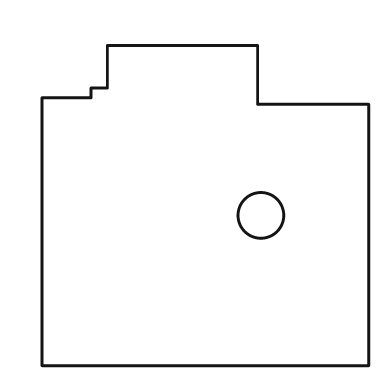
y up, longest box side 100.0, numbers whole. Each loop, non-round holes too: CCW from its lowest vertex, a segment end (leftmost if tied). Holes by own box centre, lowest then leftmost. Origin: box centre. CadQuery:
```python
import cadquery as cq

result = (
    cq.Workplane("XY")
    .moveTo(-50.0, -49.0)
    .lineTo(50.0, -49.0)
    .lineTo(50.0, 31.0)
    .lineTo(16.0, 31.0)
    .lineTo(16.0, 49.0)
    .lineTo(-30.0, 49.0)
    .lineTo(-30.0, 36.0)
    .lineTo(-35.0, 36.0)
    .lineTo(-35.0, 33.0)
    .lineTo(-50.0, 33.0)
    .close()
    .moveTo(17.0, -3.0)
    .circle(7.0)
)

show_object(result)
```